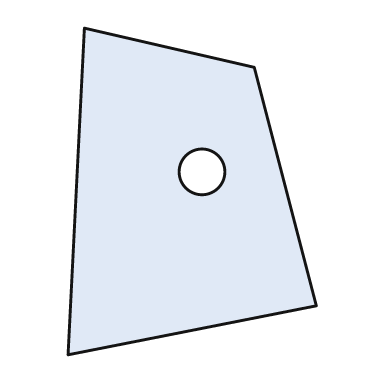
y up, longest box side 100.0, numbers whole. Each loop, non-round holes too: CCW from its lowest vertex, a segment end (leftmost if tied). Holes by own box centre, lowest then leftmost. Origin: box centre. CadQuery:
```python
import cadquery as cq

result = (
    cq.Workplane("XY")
    .moveTo(-38.0, -50.0)
    .lineTo(38.0, -35.0)
    .lineTo(19.0, 38.0)
    .lineTo(-33.0, 50.0)
    .close()
    .moveTo(3.0, 6.0)
    .circle(7.0)
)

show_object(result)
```